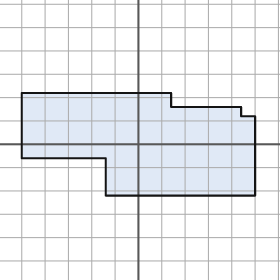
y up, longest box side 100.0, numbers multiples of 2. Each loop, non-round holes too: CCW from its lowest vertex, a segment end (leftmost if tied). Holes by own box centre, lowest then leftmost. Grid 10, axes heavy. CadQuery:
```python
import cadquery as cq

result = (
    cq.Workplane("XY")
    .moveTo(-14.0, -22.0)
    .lineTo(50.0, -22.0)
    .lineTo(50.0, 12.0)
    .lineTo(44.0, 12.0)
    .lineTo(44.0, 16.0)
    .lineTo(14.0, 16.0)
    .lineTo(14.0, 22.0)
    .lineTo(-50.0, 22.0)
    .lineTo(-50.0, -6.0)
    .lineTo(-14.0, -6.0)
    .close()
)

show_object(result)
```